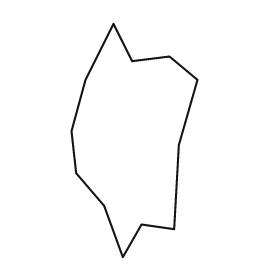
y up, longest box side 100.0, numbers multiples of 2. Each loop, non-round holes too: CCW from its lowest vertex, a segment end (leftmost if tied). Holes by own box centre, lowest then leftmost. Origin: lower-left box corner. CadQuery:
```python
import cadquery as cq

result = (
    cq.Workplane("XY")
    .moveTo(22.0, 0.0)
    .lineTo(30.0, 14.0)
    .lineTo(44.0, 12.0)
    .lineTo(46.0, 48.0)
    .lineTo(54.0, 76.0)
    .lineTo(42.0, 86.0)
    .lineTo(26.0, 84.0)
    .lineTo(18.0, 100.0)
    .lineTo(6.0, 76.0)
    .lineTo(0.0, 54.0)
    .lineTo(2.0, 36.0)
    .lineTo(14.0, 22.0)
    .close()
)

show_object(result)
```